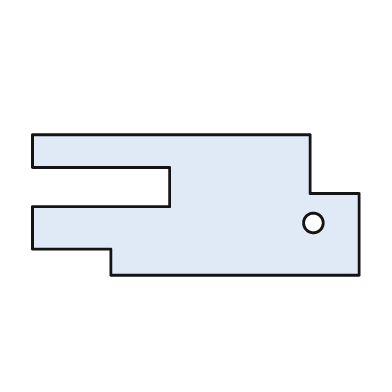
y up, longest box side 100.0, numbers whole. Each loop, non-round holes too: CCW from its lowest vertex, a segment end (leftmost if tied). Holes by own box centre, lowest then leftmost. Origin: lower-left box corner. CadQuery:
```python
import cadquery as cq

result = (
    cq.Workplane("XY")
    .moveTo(24.0, 0.0)
    .lineTo(100.0, 0.0)
    .lineTo(100.0, 25.0)
    .lineTo(85.0, 25.0)
    .lineTo(85.0, 43.0)
    .lineTo(0.0, 43.0)
    .lineTo(0.0, 33.0)
    .lineTo(42.0, 33.0)
    .lineTo(42.0, 21.0)
    .lineTo(0.0, 21.0)
    .lineTo(0.0, 8.0)
    .lineTo(24.0, 8.0)
    .close()
    .moveTo(86.0, 16.0)
    .circle(3.0)
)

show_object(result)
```